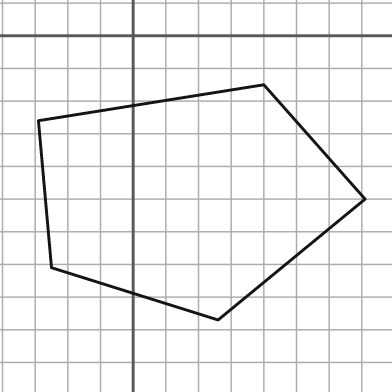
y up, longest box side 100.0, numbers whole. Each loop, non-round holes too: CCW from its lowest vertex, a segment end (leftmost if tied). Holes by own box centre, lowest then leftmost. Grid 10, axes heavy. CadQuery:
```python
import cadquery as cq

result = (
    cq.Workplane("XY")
    .moveTo(26.0, -87.0)
    .lineTo(71.0, -50.0)
    .lineTo(40.0, -15.0)
    .lineTo(-29.0, -26.0)
    .lineTo(-25.0, -71.0)
    .close()
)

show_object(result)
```